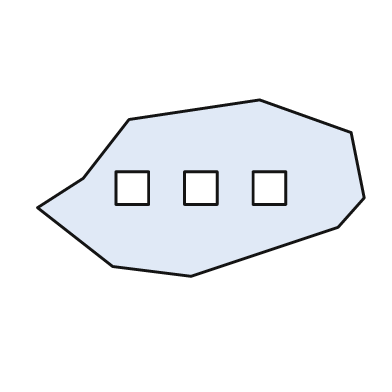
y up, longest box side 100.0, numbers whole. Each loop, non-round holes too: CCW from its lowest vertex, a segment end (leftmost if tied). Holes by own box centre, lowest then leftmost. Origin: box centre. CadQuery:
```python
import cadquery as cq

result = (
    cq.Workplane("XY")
    .moveTo(-3.0, -27.0)
    .lineTo(42.0, -12.0)
    .lineTo(50.0, -3.0)
    .lineTo(46.0, 17.0)
    .lineTo(18.0, 27.0)
    .lineTo(-22.0, 21.0)
    .lineTo(-36.0, 3.0)
    .lineTo(-50.0, -6.0)
    .lineTo(-27.0, -24.0)
    .close()
    .moveTo(-26.0, -5.0)
    .lineTo(-16.0, -5.0)
    .lineTo(-16.0, 5.0)
    .lineTo(-26.0, 5.0)
    .close()
    .moveTo(-5.0, -5.0)
    .lineTo(5.0, -5.0)
    .lineTo(5.0, 5.0)
    .lineTo(-5.0, 5.0)
    .close()
    .moveTo(16.0, -5.0)
    .lineTo(26.0, -5.0)
    .lineTo(26.0, 5.0)
    .lineTo(16.0, 5.0)
    .close()
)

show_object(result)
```